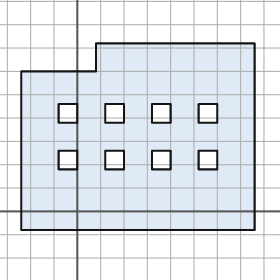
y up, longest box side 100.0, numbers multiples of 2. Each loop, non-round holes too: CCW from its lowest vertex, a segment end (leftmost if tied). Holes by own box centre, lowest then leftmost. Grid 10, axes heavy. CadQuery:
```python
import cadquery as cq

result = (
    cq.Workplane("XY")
    .moveTo(-24.0, -8.0)
    .lineTo(76.0, -8.0)
    .lineTo(76.0, 72.0)
    .lineTo(8.0, 72.0)
    .lineTo(8.0, 60.0)
    .lineTo(-24.0, 60.0)
    .close()
    .moveTo(-8.0, 18.0)
    .lineTo(0.0, 18.0)
    .lineTo(0.0, 26.0)
    .lineTo(-8.0, 26.0)
    .close()
    .moveTo(12.0, 18.0)
    .lineTo(20.0, 18.0)
    .lineTo(20.0, 26.0)
    .lineTo(12.0, 26.0)
    .close()
    .moveTo(32.0, 18.0)
    .lineTo(40.0, 18.0)
    .lineTo(40.0, 26.0)
    .lineTo(32.0, 26.0)
    .close()
    .moveTo(52.0, 18.0)
    .lineTo(60.0, 18.0)
    .lineTo(60.0, 26.0)
    .lineTo(52.0, 26.0)
    .close()
    .moveTo(-8.0, 38.0)
    .lineTo(0.0, 38.0)
    .lineTo(0.0, 46.0)
    .lineTo(-8.0, 46.0)
    .close()
    .moveTo(12.0, 38.0)
    .lineTo(20.0, 38.0)
    .lineTo(20.0, 46.0)
    .lineTo(12.0, 46.0)
    .close()
    .moveTo(32.0, 38.0)
    .lineTo(40.0, 38.0)
    .lineTo(40.0, 46.0)
    .lineTo(32.0, 46.0)
    .close()
    .moveTo(52.0, 38.0)
    .lineTo(60.0, 38.0)
    .lineTo(60.0, 46.0)
    .lineTo(52.0, 46.0)
    .close()
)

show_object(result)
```